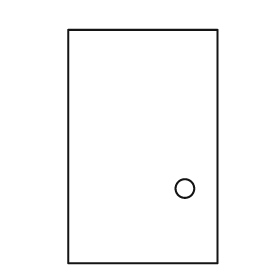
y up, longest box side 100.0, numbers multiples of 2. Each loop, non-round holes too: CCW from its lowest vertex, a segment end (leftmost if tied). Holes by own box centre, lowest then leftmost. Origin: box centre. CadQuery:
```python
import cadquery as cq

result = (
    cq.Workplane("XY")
    .moveTo(-32.0, -50.0)
    .lineTo(32.0, -50.0)
    .lineTo(32.0, 50.0)
    .lineTo(-32.0, 50.0)
    .close()
    .moveTo(18.0, -18.0)
    .circle(4.0)
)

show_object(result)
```